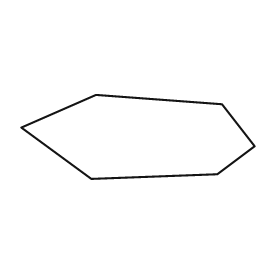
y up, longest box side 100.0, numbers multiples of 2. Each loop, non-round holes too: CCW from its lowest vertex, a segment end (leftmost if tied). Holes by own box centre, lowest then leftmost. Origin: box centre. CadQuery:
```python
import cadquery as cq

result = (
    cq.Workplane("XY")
    .moveTo(-20.0, -18.0)
    .lineTo(34.0, -16.0)
    .lineTo(50.0, -4.0)
    .lineTo(36.0, 14.0)
    .lineTo(-18.0, 18.0)
    .lineTo(-50.0, 4.0)
    .close()
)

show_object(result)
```